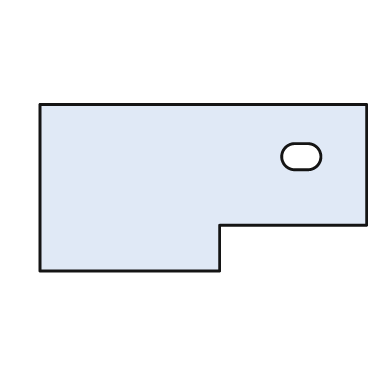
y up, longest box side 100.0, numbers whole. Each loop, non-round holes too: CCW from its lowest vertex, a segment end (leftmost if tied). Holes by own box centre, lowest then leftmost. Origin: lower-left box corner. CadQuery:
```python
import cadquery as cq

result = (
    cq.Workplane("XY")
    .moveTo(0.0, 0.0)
    .lineTo(55.0, 0.0)
    .lineTo(55.0, 14.0)
    .lineTo(100.0, 14.0)
    .lineTo(100.0, 51.0)
    .lineTo(0.0, 51.0)
    .close()
    .moveTo(78.0, 31.0)
    .lineTo(82.0, 31.0)
    .threePointArc((86.0, 35.0), (82.0, 39.0))
    .lineTo(78.0, 39.0)
    .threePointArc((74.0, 35.0), (78.0, 31.0))
    .close()
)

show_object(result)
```